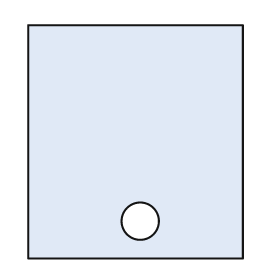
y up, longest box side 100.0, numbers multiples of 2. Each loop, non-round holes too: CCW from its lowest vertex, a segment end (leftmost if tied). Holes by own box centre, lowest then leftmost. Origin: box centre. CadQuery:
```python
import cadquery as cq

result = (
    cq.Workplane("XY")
    .moveTo(-46.0, -50.0)
    .lineTo(46.0, -50.0)
    .lineTo(46.0, 50.0)
    .lineTo(-46.0, 50.0)
    .close()
    .moveTo(2.0, -34.0)
    .circle(8.0)
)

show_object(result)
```